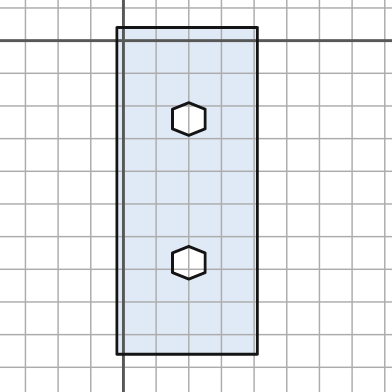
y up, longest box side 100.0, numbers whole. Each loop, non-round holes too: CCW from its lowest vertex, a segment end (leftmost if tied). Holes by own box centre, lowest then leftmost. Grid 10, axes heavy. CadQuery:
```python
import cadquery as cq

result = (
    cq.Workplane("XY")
    .moveTo(-2.0, -96.0)
    .lineTo(41.0, -96.0)
    .lineTo(41.0, 4.0)
    .lineTo(-2.0, 4.0)
    .close()
    .moveTo(20.0, -73.0)
    .lineTo(25.0, -71.0)
    .lineTo(25.0, -65.0)
    .lineTo(20.0, -63.0)
    .lineTo(15.0, -65.0)
    .lineTo(15.0, -71.0)
    .close()
    .moveTo(20.0, -29.0)
    .lineTo(25.0, -27.0)
    .lineTo(25.0, -21.0)
    .lineTo(20.0, -19.0)
    .lineTo(15.0, -21.0)
    .lineTo(15.0, -27.0)
    .close()
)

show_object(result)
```